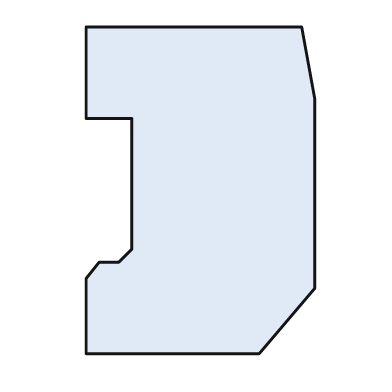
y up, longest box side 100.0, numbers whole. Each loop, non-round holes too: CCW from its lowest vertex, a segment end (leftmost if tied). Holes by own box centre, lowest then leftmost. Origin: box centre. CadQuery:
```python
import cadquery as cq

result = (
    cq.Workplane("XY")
    .moveTo(-35.0, -50.0)
    .lineTo(18.0, -50.0)
    .lineTo(35.0, -30.0)
    .lineTo(35.0, 28.0)
    .lineTo(31.0, 50.0)
    .lineTo(-35.0, 50.0)
    .lineTo(-35.0, 22.0)
    .lineTo(-21.0, 22.0)
    .lineTo(-21.0, -18.0)
    .lineTo(-25.0, -22.0)
    .lineTo(-31.0, -22.0)
    .lineTo(-35.0, -27.0)
    .close()
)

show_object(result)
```